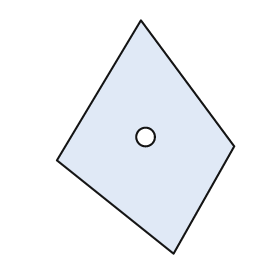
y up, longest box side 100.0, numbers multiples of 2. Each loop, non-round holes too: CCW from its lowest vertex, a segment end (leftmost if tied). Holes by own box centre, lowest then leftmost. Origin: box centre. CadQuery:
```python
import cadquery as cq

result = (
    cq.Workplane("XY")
    .moveTo(12.0, -50.0)
    .lineTo(38.0, -4.0)
    .lineTo(-2.0, 50.0)
    .lineTo(-38.0, -10.0)
    .close()
    .moveTo(0.0, 0.0)
    .circle(4.0)
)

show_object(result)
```